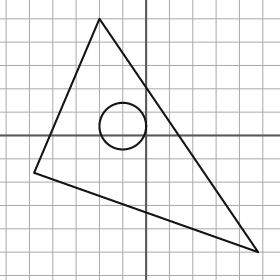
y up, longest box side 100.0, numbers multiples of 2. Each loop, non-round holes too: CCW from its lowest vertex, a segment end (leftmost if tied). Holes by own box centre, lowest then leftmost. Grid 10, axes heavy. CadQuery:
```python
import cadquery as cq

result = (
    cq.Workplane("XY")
    .moveTo(48.0, -50.0)
    .lineTo(-20.0, 50.0)
    .lineTo(-48.0, -16.0)
    .close()
    .moveTo(-10.0, 4.0)
    .circle(10.0)
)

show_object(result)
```